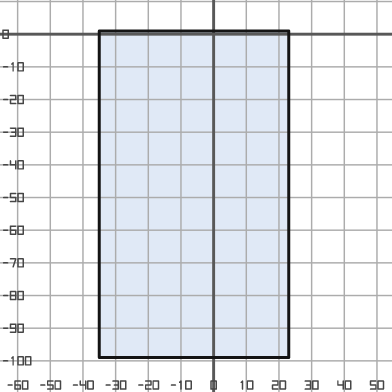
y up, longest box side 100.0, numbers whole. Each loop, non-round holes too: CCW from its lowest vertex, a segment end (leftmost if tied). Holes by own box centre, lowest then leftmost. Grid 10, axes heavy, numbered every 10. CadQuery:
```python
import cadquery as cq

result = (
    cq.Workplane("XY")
    .moveTo(-35.0, -99.0)
    .lineTo(23.0, -99.0)
    .lineTo(23.0, 1.0)
    .lineTo(-35.0, 1.0)
    .close()
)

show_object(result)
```